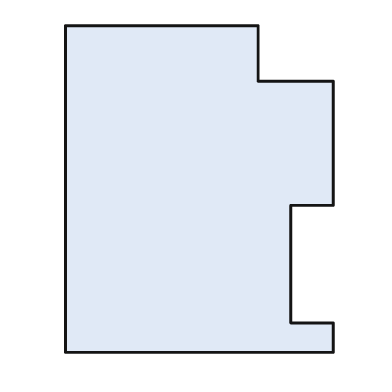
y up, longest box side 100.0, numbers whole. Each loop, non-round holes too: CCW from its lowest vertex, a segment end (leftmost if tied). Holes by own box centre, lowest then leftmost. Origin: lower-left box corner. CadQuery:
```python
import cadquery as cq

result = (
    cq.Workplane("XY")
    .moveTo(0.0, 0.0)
    .lineTo(82.0, 0.0)
    .lineTo(82.0, 9.0)
    .lineTo(69.0, 9.0)
    .lineTo(69.0, 45.0)
    .lineTo(82.0, 45.0)
    .lineTo(82.0, 83.0)
    .lineTo(59.0, 83.0)
    .lineTo(59.0, 100.0)
    .lineTo(0.0, 100.0)
    .close()
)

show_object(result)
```